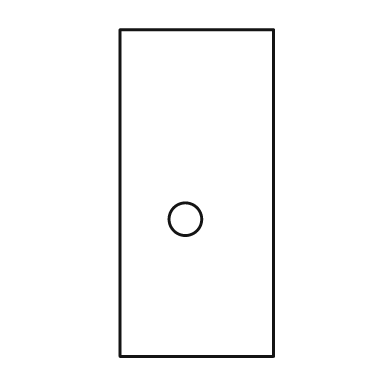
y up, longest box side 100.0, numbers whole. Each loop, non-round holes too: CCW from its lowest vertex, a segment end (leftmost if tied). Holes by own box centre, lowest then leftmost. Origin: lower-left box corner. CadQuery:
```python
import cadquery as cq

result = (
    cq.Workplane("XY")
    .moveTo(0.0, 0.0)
    .lineTo(47.0, 0.0)
    .lineTo(47.0, 100.0)
    .lineTo(0.0, 100.0)
    .close()
    .moveTo(20.0, 42.0)
    .circle(5.0)
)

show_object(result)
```